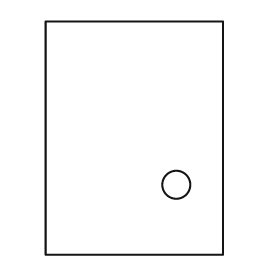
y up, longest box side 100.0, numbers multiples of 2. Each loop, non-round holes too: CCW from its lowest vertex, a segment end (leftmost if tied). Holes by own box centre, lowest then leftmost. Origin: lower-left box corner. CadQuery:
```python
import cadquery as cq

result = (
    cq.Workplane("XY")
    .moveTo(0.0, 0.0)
    .lineTo(76.0, 0.0)
    .lineTo(76.0, 100.0)
    .lineTo(0.0, 100.0)
    .close()
    .moveTo(56.0, 30.0)
    .circle(6.0)
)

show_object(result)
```